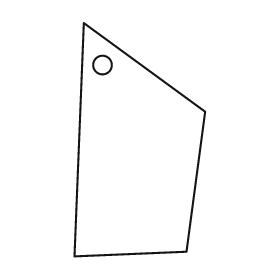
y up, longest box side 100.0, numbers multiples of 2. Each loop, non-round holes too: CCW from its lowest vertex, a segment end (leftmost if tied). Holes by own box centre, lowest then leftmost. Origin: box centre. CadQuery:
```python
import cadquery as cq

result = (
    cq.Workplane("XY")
    .moveTo(-28.0, -50.0)
    .lineTo(20.0, -48.0)
    .lineTo(28.0, 12.0)
    .lineTo(-24.0, 50.0)
    .close()
    .moveTo(-16.0, 32.0)
    .circle(4.0)
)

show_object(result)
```